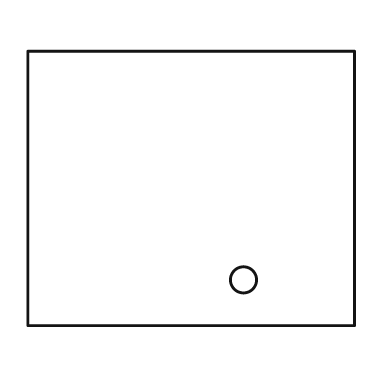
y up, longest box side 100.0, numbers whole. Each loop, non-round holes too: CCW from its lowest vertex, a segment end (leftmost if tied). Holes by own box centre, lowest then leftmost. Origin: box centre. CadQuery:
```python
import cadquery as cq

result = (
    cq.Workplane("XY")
    .moveTo(-50.0, -42.0)
    .lineTo(50.0, -42.0)
    .lineTo(50.0, 42.0)
    .lineTo(-50.0, 42.0)
    .close()
    .moveTo(16.0, -28.0)
    .circle(4.0)
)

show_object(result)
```